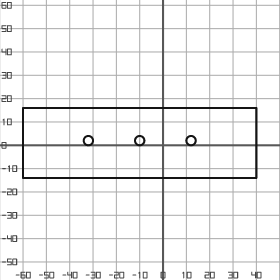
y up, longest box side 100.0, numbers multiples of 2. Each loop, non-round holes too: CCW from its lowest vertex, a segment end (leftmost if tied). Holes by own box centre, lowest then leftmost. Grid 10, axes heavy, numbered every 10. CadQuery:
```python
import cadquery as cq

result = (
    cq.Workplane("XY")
    .moveTo(-60.0, -14.0)
    .lineTo(40.0, -14.0)
    .lineTo(40.0, 16.0)
    .lineTo(-60.0, 16.0)
    .close()
    .moveTo(-32.0, 2.0)
    .circle(2.0)
    .moveTo(-10.0, 2.0)
    .circle(2.0)
    .moveTo(12.0, 2.0)
    .circle(2.0)
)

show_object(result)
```